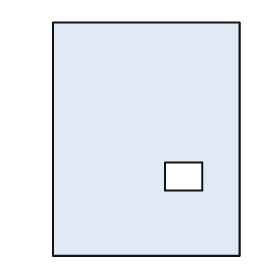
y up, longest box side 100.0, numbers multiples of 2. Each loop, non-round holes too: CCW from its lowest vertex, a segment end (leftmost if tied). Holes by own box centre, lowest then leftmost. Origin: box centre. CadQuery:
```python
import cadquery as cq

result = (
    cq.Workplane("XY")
    .moveTo(-40.0, -50.0)
    .lineTo(40.0, -50.0)
    .lineTo(40.0, 50.0)
    .lineTo(-40.0, 50.0)
    .close()
    .moveTo(8.0, -22.0)
    .lineTo(24.0, -22.0)
    .lineTo(24.0, -10.0)
    .lineTo(8.0, -10.0)
    .close()
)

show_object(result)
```